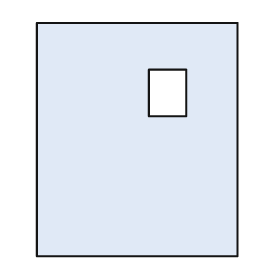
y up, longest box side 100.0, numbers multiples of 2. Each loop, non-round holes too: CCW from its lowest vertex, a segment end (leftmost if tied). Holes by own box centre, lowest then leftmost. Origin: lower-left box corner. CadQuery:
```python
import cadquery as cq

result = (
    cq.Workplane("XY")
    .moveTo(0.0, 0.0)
    .lineTo(86.0, 0.0)
    .lineTo(86.0, 100.0)
    .lineTo(0.0, 100.0)
    .close()
    .moveTo(48.0, 60.0)
    .lineTo(64.0, 60.0)
    .lineTo(64.0, 80.0)
    .lineTo(48.0, 80.0)
    .close()
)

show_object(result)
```